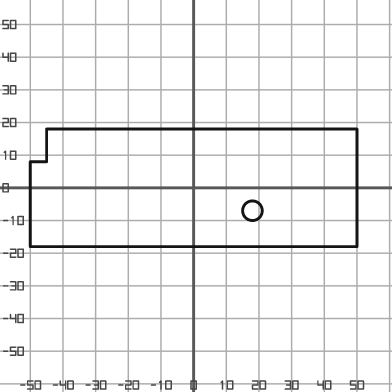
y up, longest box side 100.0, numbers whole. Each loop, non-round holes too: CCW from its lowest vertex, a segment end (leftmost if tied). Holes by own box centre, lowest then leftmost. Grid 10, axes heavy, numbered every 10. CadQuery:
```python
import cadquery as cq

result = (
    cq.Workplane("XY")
    .moveTo(-50.0, -18.0)
    .lineTo(50.0, -18.0)
    .lineTo(50.0, 18.0)
    .lineTo(-45.0, 18.0)
    .lineTo(-45.0, 8.0)
    .lineTo(-50.0, 8.0)
    .close()
    .moveTo(18.0, -7.0)
    .circle(3.0)
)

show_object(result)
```